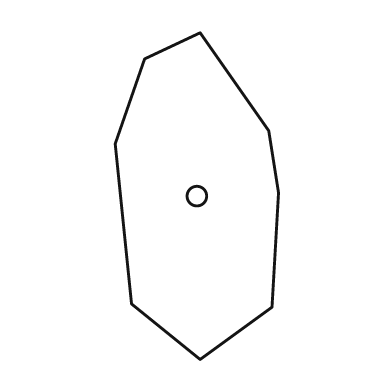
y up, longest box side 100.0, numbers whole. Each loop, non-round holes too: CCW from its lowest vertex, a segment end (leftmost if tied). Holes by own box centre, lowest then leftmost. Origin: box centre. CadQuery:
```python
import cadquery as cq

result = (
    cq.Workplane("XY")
    .moveTo(1.0, -50.0)
    .lineTo(23.0, -34.0)
    .lineTo(25.0, 1.0)
    .lineTo(22.0, 20.0)
    .lineTo(1.0, 50.0)
    .lineTo(-16.0, 42.0)
    .lineTo(-25.0, 16.0)
    .lineTo(-20.0, -33.0)
    .close()
    .moveTo(0.0, 0.0)
    .circle(3.0)
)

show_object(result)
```